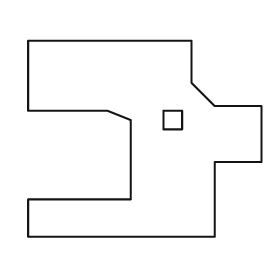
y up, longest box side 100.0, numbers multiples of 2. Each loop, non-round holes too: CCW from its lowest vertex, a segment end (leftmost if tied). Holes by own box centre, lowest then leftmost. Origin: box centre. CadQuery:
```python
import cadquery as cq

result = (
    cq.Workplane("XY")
    .moveTo(-50.0, -42.0)
    .lineTo(30.0, -42.0)
    .lineTo(30.0, -10.0)
    .lineTo(50.0, -10.0)
    .lineTo(50.0, 14.0)
    .lineTo(30.0, 14.0)
    .lineTo(20.0, 24.0)
    .lineTo(20.0, 42.0)
    .lineTo(-50.0, 42.0)
    .lineTo(-50.0, 12.0)
    .lineTo(-16.0, 12.0)
    .lineTo(-6.0, 8.0)
    .lineTo(-6.0, -26.0)
    .lineTo(-50.0, -26.0)
    .close()
    .moveTo(8.0, 4.0)
    .lineTo(16.0, 4.0)
    .lineTo(16.0, 12.0)
    .lineTo(8.0, 12.0)
    .close()
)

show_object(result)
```